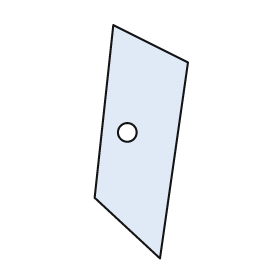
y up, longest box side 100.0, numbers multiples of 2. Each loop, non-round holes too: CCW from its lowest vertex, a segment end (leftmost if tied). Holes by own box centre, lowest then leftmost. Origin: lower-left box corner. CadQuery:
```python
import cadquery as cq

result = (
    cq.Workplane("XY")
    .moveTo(28.0, 0.0)
    .lineTo(40.0, 84.0)
    .lineTo(8.0, 100.0)
    .lineTo(0.0, 26.0)
    .close()
    .moveTo(14.0, 54.0)
    .circle(4.0)
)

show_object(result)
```